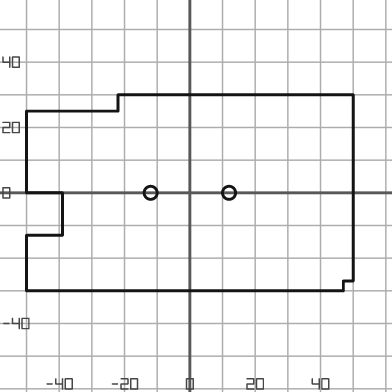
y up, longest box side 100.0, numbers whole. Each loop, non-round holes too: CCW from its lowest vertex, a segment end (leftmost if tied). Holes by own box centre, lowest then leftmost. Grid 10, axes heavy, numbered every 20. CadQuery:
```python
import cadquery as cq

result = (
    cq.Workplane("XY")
    .moveTo(-50.0, -30.0)
    .lineTo(47.0, -30.0)
    .lineTo(47.0, -27.0)
    .lineTo(50.0, -27.0)
    .lineTo(50.0, 30.0)
    .lineTo(-22.0, 30.0)
    .lineTo(-22.0, 25.0)
    .lineTo(-50.0, 25.0)
    .lineTo(-50.0, 0.0)
    .lineTo(-39.0, 0.0)
    .lineTo(-39.0, -13.0)
    .lineTo(-50.0, -13.0)
    .close()
    .moveTo(-12.0, 0.0)
    .circle(2.0)
    .moveTo(12.0, 0.0)
    .circle(2.0)
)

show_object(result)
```